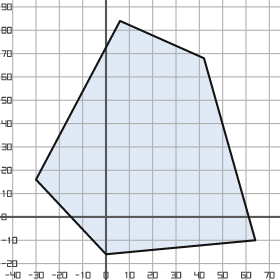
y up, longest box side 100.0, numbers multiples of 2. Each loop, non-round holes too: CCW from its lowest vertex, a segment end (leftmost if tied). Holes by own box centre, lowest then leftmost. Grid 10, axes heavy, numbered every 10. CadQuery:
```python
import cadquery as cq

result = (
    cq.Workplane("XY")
    .moveTo(0.0, -16.0)
    .lineTo(64.0, -10.0)
    .lineTo(42.0, 68.0)
    .lineTo(6.0, 84.0)
    .lineTo(-30.0, 16.0)
    .close()
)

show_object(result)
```